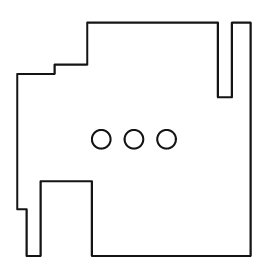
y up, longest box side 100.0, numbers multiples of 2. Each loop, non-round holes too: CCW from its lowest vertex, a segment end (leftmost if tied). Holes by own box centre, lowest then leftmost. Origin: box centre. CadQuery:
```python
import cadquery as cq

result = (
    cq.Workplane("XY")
    .moveTo(-46.0, -50.0)
    .lineTo(-40.0, -50.0)
    .lineTo(-40.0, -18.0)
    .lineTo(-18.0, -18.0)
    .lineTo(-18.0, -50.0)
    .lineTo(50.0, -50.0)
    .lineTo(50.0, 50.0)
    .lineTo(42.0, 50.0)
    .lineTo(42.0, 18.0)
    .lineTo(36.0, 18.0)
    .lineTo(36.0, 50.0)
    .lineTo(-20.0, 50.0)
    .lineTo(-20.0, 32.0)
    .lineTo(-34.0, 32.0)
    .lineTo(-34.0, 28.0)
    .lineTo(-50.0, 28.0)
    .lineTo(-50.0, -30.0)
    .lineTo(-46.0, -30.0)
    .close()
    .moveTo(-14.0, 0.0)
    .circle(4.0)
    .moveTo(0.0, 0.0)
    .circle(4.0)
    .moveTo(14.0, 0.0)
    .circle(4.0)
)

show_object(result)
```